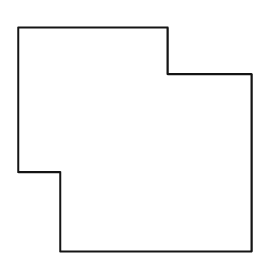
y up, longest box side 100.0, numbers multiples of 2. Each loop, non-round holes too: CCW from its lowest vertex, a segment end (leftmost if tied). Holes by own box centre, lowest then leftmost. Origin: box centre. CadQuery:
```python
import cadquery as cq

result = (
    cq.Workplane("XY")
    .moveTo(-32.0, -48.0)
    .lineTo(50.0, -48.0)
    .lineTo(50.0, 28.0)
    .lineTo(14.0, 28.0)
    .lineTo(14.0, 48.0)
    .lineTo(-50.0, 48.0)
    .lineTo(-50.0, -14.0)
    .lineTo(-32.0, -14.0)
    .close()
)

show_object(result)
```